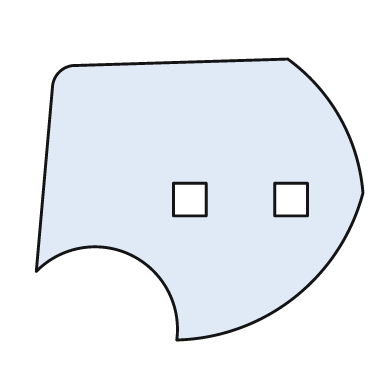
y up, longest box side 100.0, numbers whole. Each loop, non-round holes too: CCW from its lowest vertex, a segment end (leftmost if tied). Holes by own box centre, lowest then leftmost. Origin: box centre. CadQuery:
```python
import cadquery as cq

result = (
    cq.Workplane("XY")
    .moveTo(-7.0, -43.0)
    .threePointArc((29.0, -30.0), (50.0, 2.0))
    .threePointArc((43.0, 25.0), (27.0, 43.0))
    .lineTo(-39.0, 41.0)
    .threePointArc((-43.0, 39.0), (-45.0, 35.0))
    .lineTo(-50.0, -22.0)
    .threePointArc((-21.0, -17.0), (-7.0, -43.0))
    .close()
    .moveTo(-8.0, -5.0)
    .lineTo(2.0, -5.0)
    .lineTo(2.0, 5.0)
    .lineTo(-8.0, 5.0)
    .close()
    .moveTo(23.0, -5.0)
    .lineTo(33.0, -5.0)
    .lineTo(33.0, 5.0)
    .lineTo(23.0, 5.0)
    .close()
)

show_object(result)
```